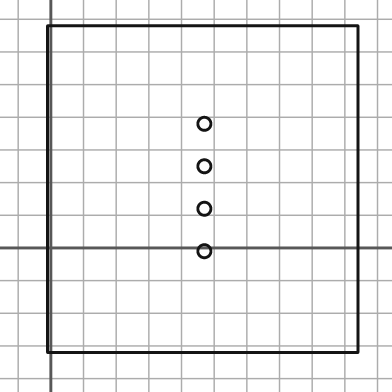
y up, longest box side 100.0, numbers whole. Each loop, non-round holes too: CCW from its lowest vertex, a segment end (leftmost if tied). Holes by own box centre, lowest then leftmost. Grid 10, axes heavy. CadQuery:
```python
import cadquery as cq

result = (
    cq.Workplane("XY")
    .moveTo(-1.0, -32.0)
    .lineTo(94.0, -32.0)
    .lineTo(94.0, 68.0)
    .lineTo(-1.0, 68.0)
    .close()
    .moveTo(47.0, -1.0)
    .circle(2.0)
    .moveTo(47.0, 12.0)
    .circle(2.0)
    .moveTo(47.0, 25.0)
    .circle(2.0)
    .moveTo(47.0, 38.0)
    .circle(2.0)
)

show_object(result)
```